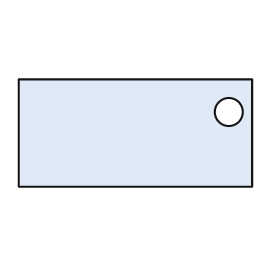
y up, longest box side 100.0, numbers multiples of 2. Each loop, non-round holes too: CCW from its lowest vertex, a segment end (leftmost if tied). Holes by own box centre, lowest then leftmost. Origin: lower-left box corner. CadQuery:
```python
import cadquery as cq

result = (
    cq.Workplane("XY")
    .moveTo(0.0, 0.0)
    .lineTo(100.0, 0.0)
    .lineTo(100.0, 46.0)
    .lineTo(0.0, 46.0)
    .close()
    .moveTo(90.0, 32.0)
    .circle(6.0)
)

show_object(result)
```